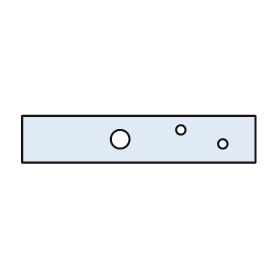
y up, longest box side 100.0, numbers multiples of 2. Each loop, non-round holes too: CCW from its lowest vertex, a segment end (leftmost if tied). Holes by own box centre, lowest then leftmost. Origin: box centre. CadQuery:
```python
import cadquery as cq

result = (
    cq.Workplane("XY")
    .moveTo(-50.0, -10.0)
    .lineTo(50.0, -10.0)
    .lineTo(50.0, 10.0)
    .lineTo(-50.0, 10.0)
    .close()
    .moveTo(36.0, -2.0)
    .circle(2.0)
    .moveTo(-8.0, 0.0)
    .circle(4.0)
    .moveTo(18.0, 4.0)
    .circle(2.0)
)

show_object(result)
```